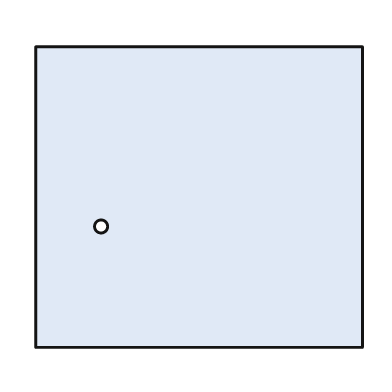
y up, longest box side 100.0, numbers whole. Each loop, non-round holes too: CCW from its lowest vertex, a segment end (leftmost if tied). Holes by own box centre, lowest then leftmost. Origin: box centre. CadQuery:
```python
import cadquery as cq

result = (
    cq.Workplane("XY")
    .moveTo(-50.0, -46.0)
    .lineTo(50.0, -46.0)
    .lineTo(50.0, 46.0)
    .lineTo(-50.0, 46.0)
    .close()
    .moveTo(-30.0, -9.0)
    .circle(2.0)
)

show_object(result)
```